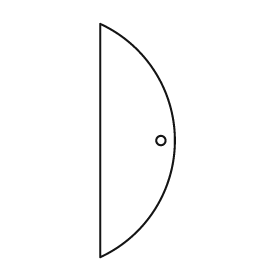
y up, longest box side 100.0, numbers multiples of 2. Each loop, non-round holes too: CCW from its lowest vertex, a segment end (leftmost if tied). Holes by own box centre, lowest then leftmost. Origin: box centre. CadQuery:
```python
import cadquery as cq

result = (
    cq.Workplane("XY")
    .moveTo(-16.0, -50.0)
    .threePointArc((16.0, 0.0), (-16.0, 50.0))
    .close()
    .moveTo(10.0, 0.0)
    .circle(2.0)
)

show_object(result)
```